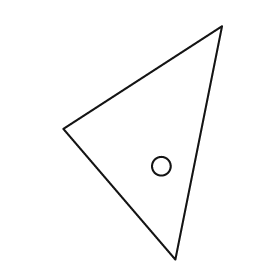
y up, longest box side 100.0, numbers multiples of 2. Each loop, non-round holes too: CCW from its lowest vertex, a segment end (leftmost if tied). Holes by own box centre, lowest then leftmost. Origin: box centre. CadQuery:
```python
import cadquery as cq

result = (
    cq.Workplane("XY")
    .moveTo(14.0, -50.0)
    .lineTo(34.0, 50.0)
    .lineTo(-34.0, 6.0)
    .close()
    .moveTo(8.0, -10.0)
    .circle(4.0)
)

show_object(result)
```